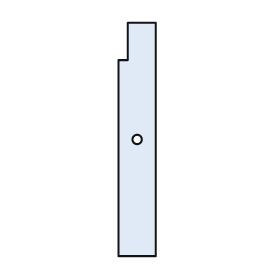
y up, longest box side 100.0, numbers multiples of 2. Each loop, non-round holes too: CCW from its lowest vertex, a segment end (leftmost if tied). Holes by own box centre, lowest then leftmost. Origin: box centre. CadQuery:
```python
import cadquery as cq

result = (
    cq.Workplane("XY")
    .moveTo(-8.0, -50.0)
    .lineTo(8.0, -50.0)
    .lineTo(8.0, 50.0)
    .lineTo(-4.0, 50.0)
    .lineTo(-4.0, 34.0)
    .lineTo(-8.0, 34.0)
    .close()
    .moveTo(0.0, 0.0)
    .circle(2.0)
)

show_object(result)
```